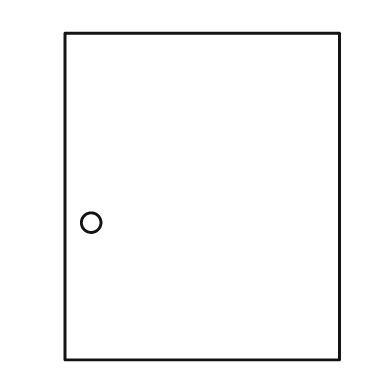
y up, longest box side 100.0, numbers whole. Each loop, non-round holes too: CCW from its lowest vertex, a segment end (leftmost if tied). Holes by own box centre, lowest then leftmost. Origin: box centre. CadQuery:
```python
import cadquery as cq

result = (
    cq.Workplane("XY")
    .moveTo(-42.0, -50.0)
    .lineTo(42.0, -50.0)
    .lineTo(42.0, 50.0)
    .lineTo(-42.0, 50.0)
    .close()
    .moveTo(-34.0, -8.0)
    .circle(3.0)
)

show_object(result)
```